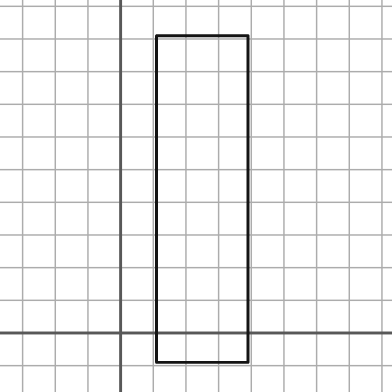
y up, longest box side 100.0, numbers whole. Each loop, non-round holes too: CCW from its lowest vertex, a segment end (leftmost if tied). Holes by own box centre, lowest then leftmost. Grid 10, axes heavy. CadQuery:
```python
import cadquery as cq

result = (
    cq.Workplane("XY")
    .moveTo(11.0, -9.0)
    .lineTo(39.0, -9.0)
    .lineTo(39.0, 91.0)
    .lineTo(11.0, 91.0)
    .close()
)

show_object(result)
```